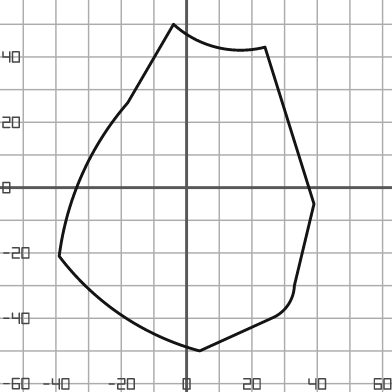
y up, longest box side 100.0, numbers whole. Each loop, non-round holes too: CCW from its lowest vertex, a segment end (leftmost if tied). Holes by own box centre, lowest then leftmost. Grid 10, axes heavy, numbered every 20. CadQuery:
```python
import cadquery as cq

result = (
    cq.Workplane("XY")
    .moveTo(4.0, -50.0)
    .lineTo(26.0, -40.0)
    .threePointArc((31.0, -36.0), (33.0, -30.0))
    .lineTo(39.0, -5.0)
    .lineTo(24.0, 43.0)
    .threePointArc((9.0, 43.0), (-4.0, 50.0))
    .lineTo(-18.0, 26.0)
    .threePointArc((-32.0, 4.0), (-39.0, -21.0))
    .threePointArc((-20.0, -39.0), (4.0, -50.0))
    .close()
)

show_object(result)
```